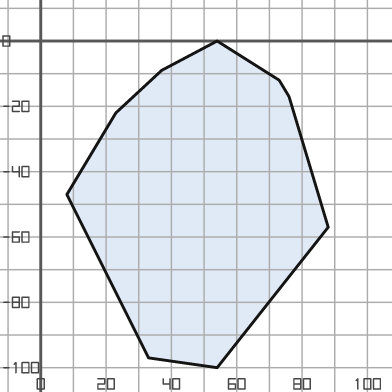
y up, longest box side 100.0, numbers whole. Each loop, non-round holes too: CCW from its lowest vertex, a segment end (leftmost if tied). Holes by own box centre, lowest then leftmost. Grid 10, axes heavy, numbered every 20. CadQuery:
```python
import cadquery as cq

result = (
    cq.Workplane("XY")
    .moveTo(54.0, -100.0)
    .lineTo(88.0, -57.0)
    .lineTo(76.0, -17.0)
    .lineTo(73.0, -12.0)
    .lineTo(54.0, 0.0)
    .lineTo(37.0, -9.0)
    .lineTo(23.0, -22.0)
    .lineTo(8.0, -47.0)
    .lineTo(33.0, -97.0)
    .close()
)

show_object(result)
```